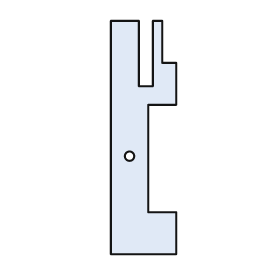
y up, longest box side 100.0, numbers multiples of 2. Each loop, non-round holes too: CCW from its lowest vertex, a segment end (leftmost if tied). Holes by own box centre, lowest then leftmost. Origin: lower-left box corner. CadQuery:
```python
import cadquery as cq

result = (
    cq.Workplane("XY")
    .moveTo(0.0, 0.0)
    .lineTo(28.0, 0.0)
    .lineTo(28.0, 18.0)
    .lineTo(16.0, 18.0)
    .lineTo(16.0, 64.0)
    .lineTo(28.0, 64.0)
    .lineTo(28.0, 82.0)
    .lineTo(22.0, 82.0)
    .lineTo(22.0, 100.0)
    .lineTo(18.0, 100.0)
    .lineTo(18.0, 72.0)
    .lineTo(12.0, 72.0)
    .lineTo(12.0, 100.0)
    .lineTo(0.0, 100.0)
    .close()
    .moveTo(8.0, 42.0)
    .circle(2.0)
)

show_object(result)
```